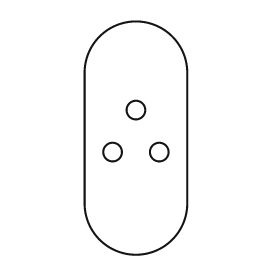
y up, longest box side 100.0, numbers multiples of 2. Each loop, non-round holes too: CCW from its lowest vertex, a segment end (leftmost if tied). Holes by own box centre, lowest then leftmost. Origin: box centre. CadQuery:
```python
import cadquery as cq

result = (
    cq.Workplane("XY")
    .moveTo(-22.0, -28.0)
    .threePointArc((0.0, -50.0), (22.0, -28.0))
    .lineTo(22.0, 28.0)
    .threePointArc((0.0, 50.0), (-22.0, 28.0))
    .close()
    .moveTo(-10.0, -6.0)
    .circle(4.0)
    .moveTo(10.0, -6.0)
    .circle(4.0)
    .moveTo(0.0, 12.0)
    .circle(4.0)
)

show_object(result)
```